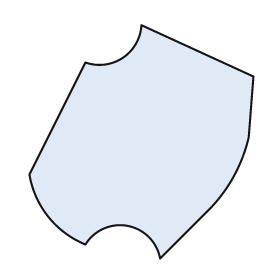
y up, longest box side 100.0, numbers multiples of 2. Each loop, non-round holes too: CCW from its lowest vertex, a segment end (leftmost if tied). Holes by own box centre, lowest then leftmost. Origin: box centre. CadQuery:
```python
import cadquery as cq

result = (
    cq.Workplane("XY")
    .moveTo(8.0, -50.0)
    .lineTo(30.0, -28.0)
    .threePointArc((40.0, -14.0), (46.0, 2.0))
    .lineTo(48.0, 28.0)
    .lineTo(0.0, 50.0)
    .threePointArc((-8.0, 36.0), (-24.0, 34.0))
    .lineTo(-48.0, -14.0)
    .threePointArc((-40.0, -32.0), (-24.0, -44.0))
    .threePointArc((-6.0, -36.0), (8.0, -50.0))
    .close()
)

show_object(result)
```